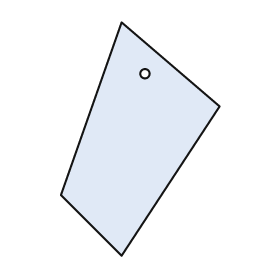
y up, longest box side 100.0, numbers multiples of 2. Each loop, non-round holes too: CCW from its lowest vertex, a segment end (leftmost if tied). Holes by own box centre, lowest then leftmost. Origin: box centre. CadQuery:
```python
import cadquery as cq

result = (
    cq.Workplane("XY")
    .moveTo(-8.0, -50.0)
    .lineTo(34.0, 14.0)
    .lineTo(-8.0, 50.0)
    .lineTo(-34.0, -24.0)
    .close()
    .moveTo(2.0, 28.0)
    .circle(2.0)
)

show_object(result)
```